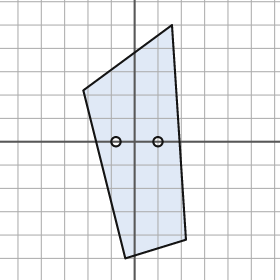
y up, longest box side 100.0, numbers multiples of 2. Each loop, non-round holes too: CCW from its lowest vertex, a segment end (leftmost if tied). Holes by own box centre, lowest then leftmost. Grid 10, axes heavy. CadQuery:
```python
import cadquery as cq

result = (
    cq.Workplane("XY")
    .moveTo(-4.0, -50.0)
    .lineTo(22.0, -42.0)
    .lineTo(16.0, 50.0)
    .lineTo(-22.0, 22.0)
    .close()
    .moveTo(-8.0, 0.0)
    .circle(2.0)
    .moveTo(10.0, 0.0)
    .circle(2.0)
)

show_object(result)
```